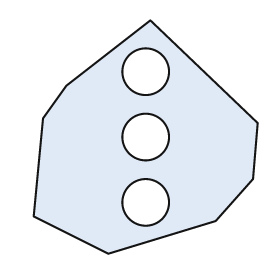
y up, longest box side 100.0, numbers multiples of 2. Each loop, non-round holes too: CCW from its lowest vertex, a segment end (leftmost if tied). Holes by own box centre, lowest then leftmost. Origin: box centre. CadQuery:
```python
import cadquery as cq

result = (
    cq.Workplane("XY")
    .moveTo(-16.0, -50.0)
    .lineTo(30.0, -36.0)
    .lineTo(46.0, -18.0)
    .lineTo(48.0, 6.0)
    .lineTo(2.0, 50.0)
    .lineTo(-34.0, 22.0)
    .lineTo(-44.0, 8.0)
    .lineTo(-48.0, -34.0)
    .close()
    .moveTo(0.0, -28.0)
    .circle(10.0)
    .moveTo(0.0, 0.0)
    .circle(10.0)
    .moveTo(0.0, 28.0)
    .circle(10.0)
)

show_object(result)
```